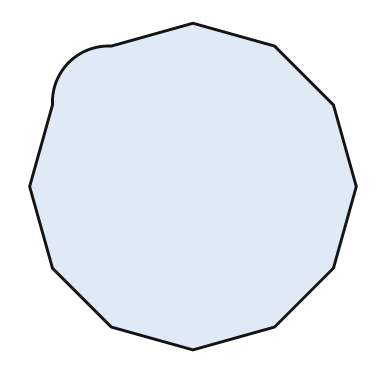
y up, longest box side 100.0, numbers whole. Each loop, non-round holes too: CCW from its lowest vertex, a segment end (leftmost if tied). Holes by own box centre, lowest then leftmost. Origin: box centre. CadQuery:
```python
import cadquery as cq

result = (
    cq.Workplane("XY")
    .moveTo(0.0, -50.0)
    .lineTo(25.0, -43.0)
    .lineTo(43.0, -25.0)
    .lineTo(50.0, 0.0)
    .lineTo(43.0, 25.0)
    .lineTo(25.0, 43.0)
    .lineTo(0.0, 50.0)
    .lineTo(-25.0, 43.0)
    .threePointArc((-38.0, 38.0), (-43.0, 25.0))
    .lineTo(-50.0, 0.0)
    .lineTo(-43.0, -25.0)
    .lineTo(-25.0, -43.0)
    .close()
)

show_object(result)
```